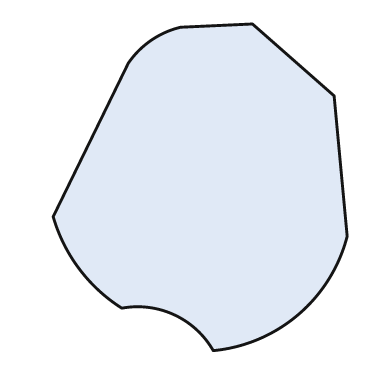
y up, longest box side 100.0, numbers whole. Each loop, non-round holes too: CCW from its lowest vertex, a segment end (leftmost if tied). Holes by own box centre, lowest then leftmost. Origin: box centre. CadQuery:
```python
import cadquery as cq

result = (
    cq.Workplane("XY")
    .moveTo(4.0, -50.0)
    .threePointArc((30.0, -39.0), (45.0, -15.0))
    .lineTo(41.0, 28.0)
    .lineTo(16.0, 50.0)
    .lineTo(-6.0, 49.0)
    .threePointArc((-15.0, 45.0), (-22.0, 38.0))
    .lineTo(-45.0, -9.0)
    .threePointArc((-37.0, -25.0), (-24.0, -37.0))
    .threePointArc((-8.0, -39.0), (4.0, -50.0))
    .close()
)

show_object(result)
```